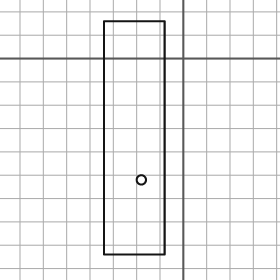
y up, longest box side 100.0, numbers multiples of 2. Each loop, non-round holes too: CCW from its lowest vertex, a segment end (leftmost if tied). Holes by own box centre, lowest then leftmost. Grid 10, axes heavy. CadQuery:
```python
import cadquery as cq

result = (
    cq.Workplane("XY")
    .moveTo(-34.0, -84.0)
    .lineTo(-8.0, -84.0)
    .lineTo(-8.0, 16.0)
    .lineTo(-34.0, 16.0)
    .close()
    .moveTo(-18.0, -52.0)
    .circle(2.0)
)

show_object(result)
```